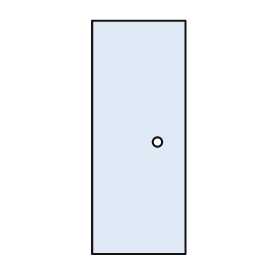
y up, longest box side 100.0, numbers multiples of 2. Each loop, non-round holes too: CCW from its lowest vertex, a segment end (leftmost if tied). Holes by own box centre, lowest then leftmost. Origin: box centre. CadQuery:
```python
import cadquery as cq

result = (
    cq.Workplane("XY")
    .moveTo(-20.0, -50.0)
    .lineTo(20.0, -50.0)
    .lineTo(20.0, 50.0)
    .lineTo(-20.0, 50.0)
    .close()
    .moveTo(8.0, -2.0)
    .circle(2.0)
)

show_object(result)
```